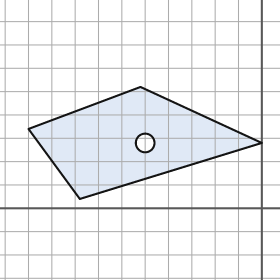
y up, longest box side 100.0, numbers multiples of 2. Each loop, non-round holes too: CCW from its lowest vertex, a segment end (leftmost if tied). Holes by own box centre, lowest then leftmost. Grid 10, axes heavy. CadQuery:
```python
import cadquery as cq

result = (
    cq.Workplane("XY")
    .moveTo(-78.0, 4.0)
    .lineTo(0.0, 28.0)
    .lineTo(-52.0, 52.0)
    .lineTo(-100.0, 34.0)
    .close()
    .moveTo(-50.0, 28.0)
    .circle(4.0)
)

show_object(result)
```